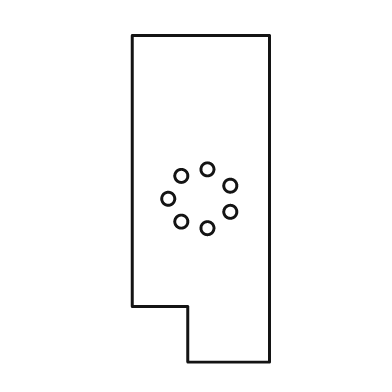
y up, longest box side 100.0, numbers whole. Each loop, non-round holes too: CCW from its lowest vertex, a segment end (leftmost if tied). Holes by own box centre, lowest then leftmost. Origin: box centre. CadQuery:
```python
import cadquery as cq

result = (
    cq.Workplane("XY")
    .moveTo(-4.0, -50.0)
    .lineTo(21.0, -50.0)
    .lineTo(21.0, 50.0)
    .lineTo(-21.0, 50.0)
    .lineTo(-21.0, -33.0)
    .lineTo(-4.0, -33.0)
    .close()
    .moveTo(2.0, -9.0)
    .circle(2.0)
    .moveTo(-6.0, -7.0)
    .circle(2.0)
    .moveTo(9.0, -4.0)
    .circle(2.0)
    .moveTo(-10.0, 0.0)
    .circle(2.0)
    .moveTo(9.0, 4.0)
    .circle(2.0)
    .moveTo(-6.0, 7.0)
    .circle(2.0)
    .moveTo(2.0, 9.0)
    .circle(2.0)
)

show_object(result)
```